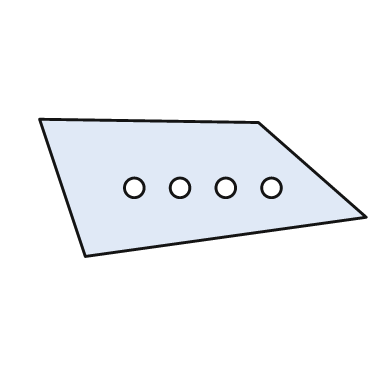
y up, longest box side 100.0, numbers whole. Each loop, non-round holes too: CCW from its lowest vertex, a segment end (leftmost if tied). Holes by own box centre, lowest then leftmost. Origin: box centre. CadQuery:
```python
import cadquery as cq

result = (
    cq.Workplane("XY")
    .moveTo(-36.0, -21.0)
    .lineTo(50.0, -9.0)
    .lineTo(17.0, 20.0)
    .lineTo(-50.0, 21.0)
    .close()
    .moveTo(-21.0, 0.0)
    .circle(3.0)
    .moveTo(-7.0, 0.0)
    .circle(3.0)
    .moveTo(7.0, 0.0)
    .circle(3.0)
    .moveTo(21.0, 0.0)
    .circle(3.0)
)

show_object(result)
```